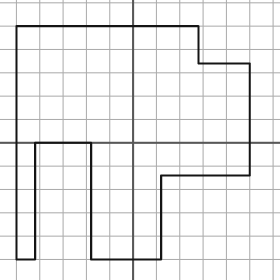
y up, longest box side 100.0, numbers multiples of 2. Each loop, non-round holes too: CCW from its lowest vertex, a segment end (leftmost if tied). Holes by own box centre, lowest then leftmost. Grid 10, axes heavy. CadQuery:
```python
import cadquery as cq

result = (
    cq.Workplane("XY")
    .moveTo(-50.0, -50.0)
    .lineTo(-42.0, -50.0)
    .lineTo(-42.0, 0.0)
    .lineTo(-18.0, 0.0)
    .lineTo(-18.0, -50.0)
    .lineTo(12.0, -50.0)
    .lineTo(12.0, -14.0)
    .lineTo(50.0, -14.0)
    .lineTo(50.0, 34.0)
    .lineTo(28.0, 34.0)
    .lineTo(28.0, 50.0)
    .lineTo(-50.0, 50.0)
    .close()
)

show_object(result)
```